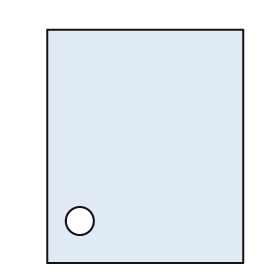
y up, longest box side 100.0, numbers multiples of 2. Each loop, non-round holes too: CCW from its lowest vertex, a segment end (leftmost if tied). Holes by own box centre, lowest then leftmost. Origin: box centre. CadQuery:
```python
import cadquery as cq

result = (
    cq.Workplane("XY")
    .moveTo(-42.0, -50.0)
    .lineTo(42.0, -50.0)
    .lineTo(42.0, 50.0)
    .lineTo(-42.0, 50.0)
    .close()
    .moveTo(-28.0, -32.0)
    .circle(6.0)
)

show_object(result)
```